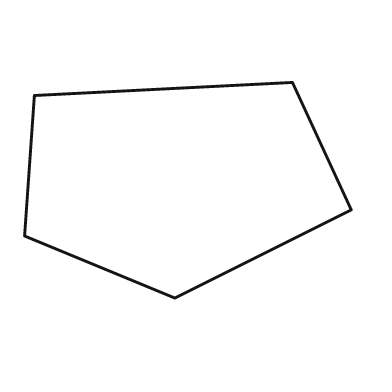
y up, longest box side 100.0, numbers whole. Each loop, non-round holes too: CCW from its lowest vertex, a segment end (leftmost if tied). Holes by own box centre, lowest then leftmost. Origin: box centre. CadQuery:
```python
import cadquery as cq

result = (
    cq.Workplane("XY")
    .moveTo(-4.0, -33.0)
    .lineTo(50.0, -6.0)
    .lineTo(32.0, 33.0)
    .lineTo(-47.0, 29.0)
    .lineTo(-50.0, -14.0)
    .close()
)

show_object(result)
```